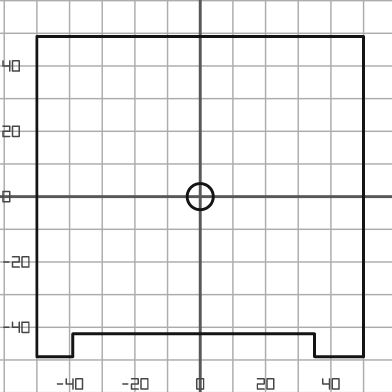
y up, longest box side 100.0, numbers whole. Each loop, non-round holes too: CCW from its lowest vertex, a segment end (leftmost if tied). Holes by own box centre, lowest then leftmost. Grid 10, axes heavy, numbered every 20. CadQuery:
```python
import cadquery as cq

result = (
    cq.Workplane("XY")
    .moveTo(-50.0, -49.0)
    .lineTo(-39.0, -49.0)
    .lineTo(-39.0, -42.0)
    .lineTo(35.0, -42.0)
    .lineTo(35.0, -49.0)
    .lineTo(50.0, -49.0)
    .lineTo(50.0, 49.0)
    .lineTo(-50.0, 49.0)
    .close()
    .moveTo(0.0, 0.0)
    .circle(4.0)
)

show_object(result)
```